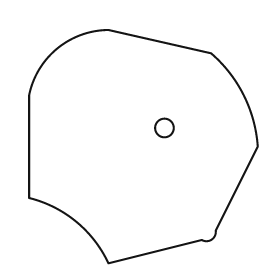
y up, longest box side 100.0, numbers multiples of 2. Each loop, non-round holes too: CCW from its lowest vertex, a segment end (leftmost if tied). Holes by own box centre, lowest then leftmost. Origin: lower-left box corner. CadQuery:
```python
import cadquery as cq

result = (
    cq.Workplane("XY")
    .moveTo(34.0, 0.0)
    .lineTo(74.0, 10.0)
    .threePointArc((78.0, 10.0), (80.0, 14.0))
    .lineTo(98.0, 50.0)
    .threePointArc((92.0, 72.0), (78.0, 90.0))
    .lineTo(34.0, 100.0)
    .threePointArc((12.0, 92.0), (0.0, 72.0))
    .lineTo(0.0, 28.0)
    .threePointArc((20.0, 18.0), (34.0, 0.0))
    .close()
    .moveTo(58.0, 58.0)
    .circle(4.0)
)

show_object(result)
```